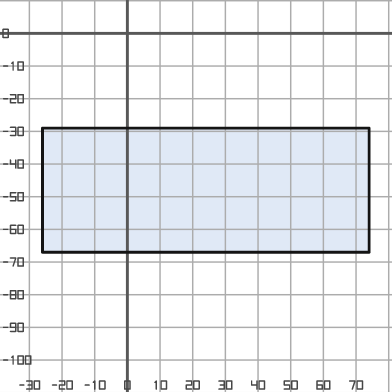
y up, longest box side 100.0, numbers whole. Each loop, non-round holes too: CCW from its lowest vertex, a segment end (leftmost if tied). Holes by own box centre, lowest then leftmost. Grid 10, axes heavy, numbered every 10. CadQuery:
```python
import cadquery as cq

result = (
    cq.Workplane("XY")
    .moveTo(-26.0, -67.0)
    .lineTo(74.0, -67.0)
    .lineTo(74.0, -29.0)
    .lineTo(-26.0, -29.0)
    .close()
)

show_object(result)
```